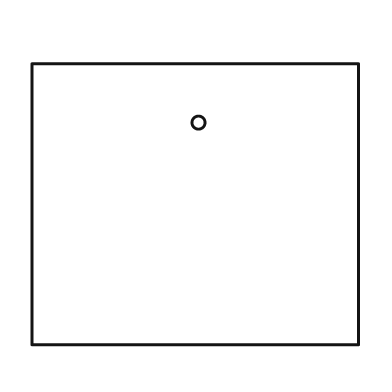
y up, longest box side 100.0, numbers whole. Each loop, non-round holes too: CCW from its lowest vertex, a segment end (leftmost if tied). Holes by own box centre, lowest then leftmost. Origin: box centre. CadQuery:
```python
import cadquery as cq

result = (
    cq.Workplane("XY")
    .moveTo(-50.0, -43.0)
    .lineTo(50.0, -43.0)
    .lineTo(50.0, 43.0)
    .lineTo(-50.0, 43.0)
    .close()
    .moveTo(1.0, 25.0)
    .circle(2.0)
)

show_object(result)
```